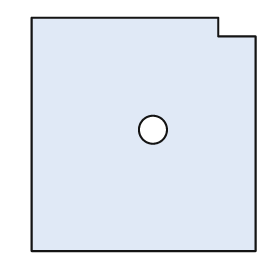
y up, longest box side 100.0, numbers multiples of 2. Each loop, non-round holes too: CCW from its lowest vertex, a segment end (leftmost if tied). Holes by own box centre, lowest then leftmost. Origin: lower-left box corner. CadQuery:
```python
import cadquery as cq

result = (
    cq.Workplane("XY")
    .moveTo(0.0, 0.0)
    .lineTo(96.0, 0.0)
    .lineTo(96.0, 92.0)
    .lineTo(80.0, 92.0)
    .lineTo(80.0, 100.0)
    .lineTo(0.0, 100.0)
    .close()
    .moveTo(52.0, 52.0)
    .circle(6.0)
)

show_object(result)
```